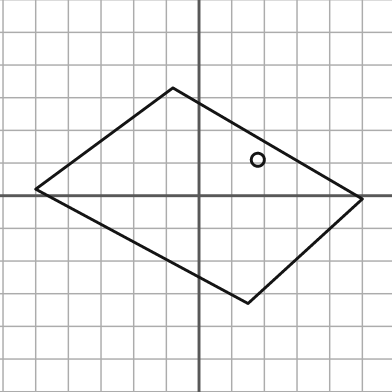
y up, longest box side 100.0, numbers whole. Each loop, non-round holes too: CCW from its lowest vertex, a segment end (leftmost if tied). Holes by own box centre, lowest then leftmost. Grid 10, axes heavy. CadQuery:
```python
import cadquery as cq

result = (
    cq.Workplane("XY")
    .moveTo(15.0, -33.0)
    .lineTo(50.0, -1.0)
    .lineTo(-8.0, 33.0)
    .lineTo(-50.0, 2.0)
    .close()
    .moveTo(18.0, 11.0)
    .circle(2.0)
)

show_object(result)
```